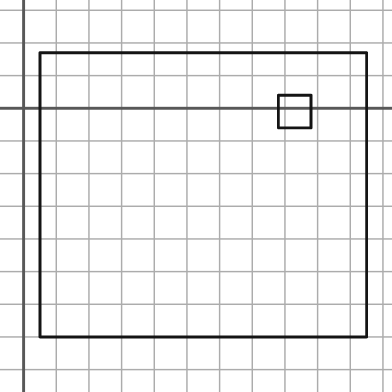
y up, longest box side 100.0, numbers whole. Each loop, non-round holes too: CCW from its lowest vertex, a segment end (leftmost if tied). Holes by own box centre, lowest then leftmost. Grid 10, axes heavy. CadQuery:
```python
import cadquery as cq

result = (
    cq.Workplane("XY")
    .moveTo(5.0, -70.0)
    .lineTo(105.0, -70.0)
    .lineTo(105.0, 17.0)
    .lineTo(5.0, 17.0)
    .close()
    .moveTo(78.0, -6.0)
    .lineTo(88.0, -6.0)
    .lineTo(88.0, 4.0)
    .lineTo(78.0, 4.0)
    .close()
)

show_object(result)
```